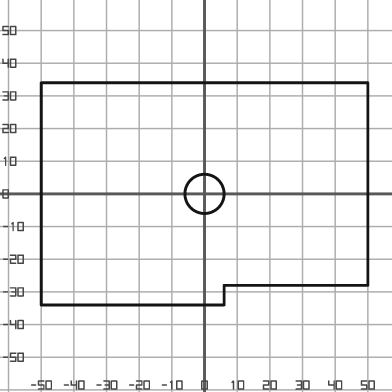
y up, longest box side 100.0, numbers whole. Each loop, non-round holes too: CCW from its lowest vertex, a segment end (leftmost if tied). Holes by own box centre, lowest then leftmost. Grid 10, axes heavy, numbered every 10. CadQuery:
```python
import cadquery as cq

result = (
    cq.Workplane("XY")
    .moveTo(-50.0, -34.0)
    .lineTo(6.0, -34.0)
    .lineTo(6.0, -28.0)
    .lineTo(50.0, -28.0)
    .lineTo(50.0, 34.0)
    .lineTo(-50.0, 34.0)
    .close()
    .moveTo(0.0, 0.0)
    .circle(6.0)
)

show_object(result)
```